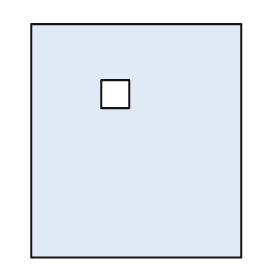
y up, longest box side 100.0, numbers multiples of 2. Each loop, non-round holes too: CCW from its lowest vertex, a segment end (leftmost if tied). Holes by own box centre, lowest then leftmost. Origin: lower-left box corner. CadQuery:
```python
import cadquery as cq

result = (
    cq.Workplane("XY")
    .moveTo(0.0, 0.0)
    .lineTo(90.0, 0.0)
    .lineTo(90.0, 100.0)
    .lineTo(0.0, 100.0)
    .close()
    .moveTo(30.0, 64.0)
    .lineTo(42.0, 64.0)
    .lineTo(42.0, 76.0)
    .lineTo(30.0, 76.0)
    .close()
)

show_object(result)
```